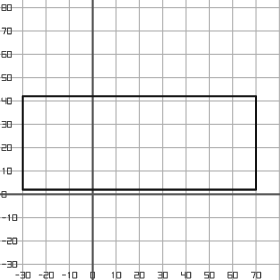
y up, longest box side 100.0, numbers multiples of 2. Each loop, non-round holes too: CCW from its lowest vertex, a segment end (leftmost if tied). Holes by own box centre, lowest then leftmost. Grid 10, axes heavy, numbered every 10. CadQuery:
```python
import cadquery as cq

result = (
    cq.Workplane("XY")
    .moveTo(-30.0, 2.0)
    .lineTo(70.0, 2.0)
    .lineTo(70.0, 42.0)
    .lineTo(-30.0, 42.0)
    .close()
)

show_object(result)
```